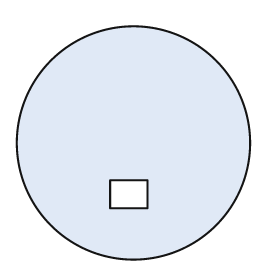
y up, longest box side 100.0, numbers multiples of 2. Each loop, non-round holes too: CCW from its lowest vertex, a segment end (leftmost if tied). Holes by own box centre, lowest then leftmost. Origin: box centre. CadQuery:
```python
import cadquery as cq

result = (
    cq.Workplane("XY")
    .moveTo(0.0, 0.0)
    .circle(50.0)
    .moveTo(-10.0, -28.0)
    .lineTo(6.0, -28.0)
    .lineTo(6.0, -16.0)
    .lineTo(-10.0, -16.0)
    .close()
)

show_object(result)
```